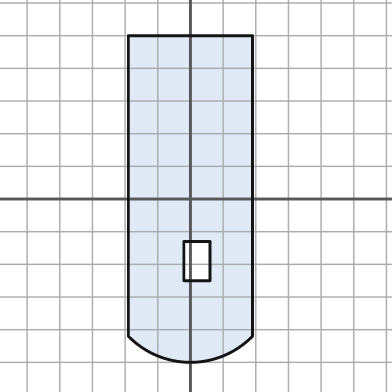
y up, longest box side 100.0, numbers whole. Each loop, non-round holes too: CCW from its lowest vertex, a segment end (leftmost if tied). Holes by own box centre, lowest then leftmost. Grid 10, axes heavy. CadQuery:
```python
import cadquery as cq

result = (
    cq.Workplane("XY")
    .moveTo(-19.0, -42.0)
    .threePointArc((0.0, -50.0), (19.0, -42.0))
    .lineTo(19.0, 50.0)
    .lineTo(-19.0, 50.0)
    .close()
    .moveTo(-2.0, -25.0)
    .lineTo(6.0, -25.0)
    .lineTo(6.0, -13.0)
    .lineTo(-2.0, -13.0)
    .close()
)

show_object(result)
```